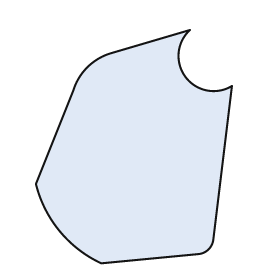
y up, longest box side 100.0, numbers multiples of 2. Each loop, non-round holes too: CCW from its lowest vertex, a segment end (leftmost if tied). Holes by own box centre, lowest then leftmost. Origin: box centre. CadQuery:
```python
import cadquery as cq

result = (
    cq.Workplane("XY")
    .moveTo(-14.0, -50.0)
    .lineTo(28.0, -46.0)
    .threePointArc((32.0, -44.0), (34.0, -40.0))
    .lineTo(42.0, 26.0)
    .threePointArc((22.0, 30.0), (24.0, 50.0))
    .lineTo(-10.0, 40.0)
    .threePointArc((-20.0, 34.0), (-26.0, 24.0))
    .lineTo(-42.0, -16.0)
    .threePointArc((-32.0, -36.0), (-14.0, -50.0))
    .close()
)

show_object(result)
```